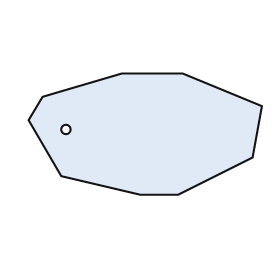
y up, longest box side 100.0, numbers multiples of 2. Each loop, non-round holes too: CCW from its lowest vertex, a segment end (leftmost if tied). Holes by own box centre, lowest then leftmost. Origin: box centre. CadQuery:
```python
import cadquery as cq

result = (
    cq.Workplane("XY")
    .moveTo(-2.0, -26.0)
    .lineTo(14.0, -26.0)
    .lineTo(46.0, -10.0)
    .lineTo(50.0, 12.0)
    .lineTo(16.0, 26.0)
    .lineTo(-10.0, 26.0)
    .lineTo(-44.0, 16.0)
    .lineTo(-50.0, 6.0)
    .lineTo(-36.0, -18.0)
    .close()
    .moveTo(-34.0, 2.0)
    .circle(2.0)
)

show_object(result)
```